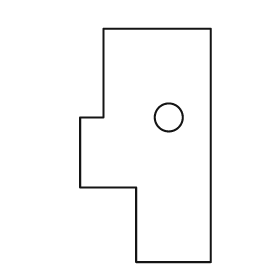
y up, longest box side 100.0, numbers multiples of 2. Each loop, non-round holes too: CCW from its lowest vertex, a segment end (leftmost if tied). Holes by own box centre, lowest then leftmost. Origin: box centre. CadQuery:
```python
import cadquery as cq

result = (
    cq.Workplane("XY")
    .moveTo(-4.0, -50.0)
    .lineTo(28.0, -50.0)
    .lineTo(28.0, 50.0)
    .lineTo(-18.0, 50.0)
    .lineTo(-18.0, 12.0)
    .lineTo(-28.0, 12.0)
    .lineTo(-28.0, -18.0)
    .lineTo(-4.0, -18.0)
    .close()
    .moveTo(10.0, 12.0)
    .circle(6.0)
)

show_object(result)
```